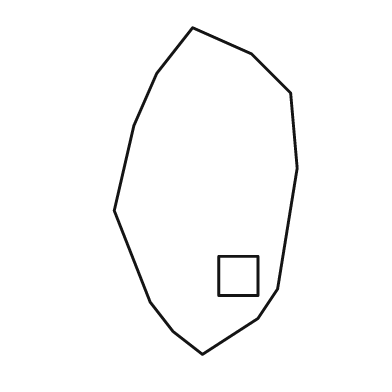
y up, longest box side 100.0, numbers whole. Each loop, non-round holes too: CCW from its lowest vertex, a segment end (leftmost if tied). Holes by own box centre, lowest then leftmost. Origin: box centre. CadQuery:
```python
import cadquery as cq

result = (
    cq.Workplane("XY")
    .moveTo(-1.0, -50.0)
    .lineTo(16.0, -39.0)
    .lineTo(22.0, -30.0)
    .lineTo(28.0, 7.0)
    .lineTo(26.0, 30.0)
    .lineTo(14.0, 42.0)
    .lineTo(-4.0, 50.0)
    .lineTo(-15.0, 36.0)
    .lineTo(-22.0, 20.0)
    .lineTo(-28.0, -6.0)
    .lineTo(-17.0, -34.0)
    .lineTo(-10.0, -43.0)
    .close()
    .moveTo(4.0, -32.0)
    .lineTo(16.0, -32.0)
    .lineTo(16.0, -20.0)
    .lineTo(4.0, -20.0)
    .close()
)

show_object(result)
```